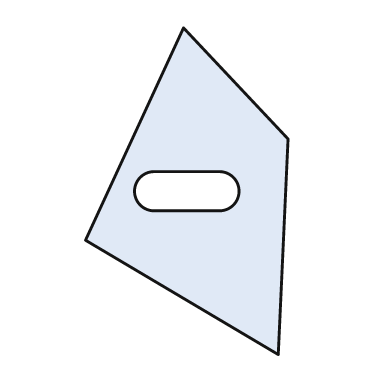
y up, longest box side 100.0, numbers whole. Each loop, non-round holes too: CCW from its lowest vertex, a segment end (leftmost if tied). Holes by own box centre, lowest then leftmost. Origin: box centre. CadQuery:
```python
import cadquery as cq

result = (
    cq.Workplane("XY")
    .moveTo(28.0, -50.0)
    .lineTo(31.0, 16.0)
    .lineTo(-1.0, 50.0)
    .lineTo(-31.0, -15.0)
    .close()
    .moveTo(-10.0, -6.0)
    .lineTo(10.0, -6.0)
    .threePointArc((16.0, 0.0), (10.0, 6.0))
    .lineTo(-10.0, 6.0)
    .threePointArc((-16.0, 0.0), (-10.0, -6.0))
    .close()
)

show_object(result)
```